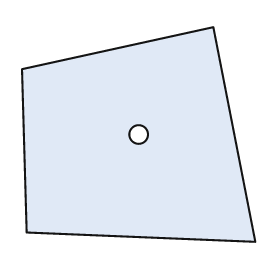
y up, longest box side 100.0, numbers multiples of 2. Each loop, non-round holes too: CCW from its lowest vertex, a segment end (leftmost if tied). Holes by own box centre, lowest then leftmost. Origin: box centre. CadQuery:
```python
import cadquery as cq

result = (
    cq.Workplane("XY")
    .moveTo(50.0, -46.0)
    .lineTo(32.0, 46.0)
    .lineTo(-50.0, 28.0)
    .lineTo(-48.0, -42.0)
    .close()
    .moveTo(0.0, 0.0)
    .circle(4.0)
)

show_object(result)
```